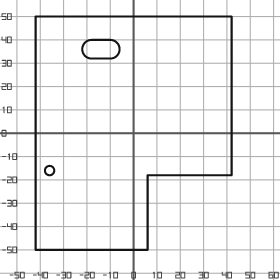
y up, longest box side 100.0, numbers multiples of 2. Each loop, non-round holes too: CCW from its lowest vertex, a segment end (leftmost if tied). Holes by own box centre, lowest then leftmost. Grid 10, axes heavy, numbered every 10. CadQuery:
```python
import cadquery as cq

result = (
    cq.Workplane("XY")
    .moveTo(-42.0, -50.0)
    .lineTo(6.0, -50.0)
    .lineTo(6.0, -18.0)
    .lineTo(42.0, -18.0)
    .lineTo(42.0, 50.0)
    .lineTo(-42.0, 50.0)
    .close()
    .moveTo(-36.0, -16.0)
    .circle(2.0)
    .moveTo(-18.0, 32.0)
    .lineTo(-10.0, 32.0)
    .threePointArc((-6.0, 36.0), (-10.0, 40.0))
    .lineTo(-18.0, 40.0)
    .threePointArc((-22.0, 36.0), (-18.0, 32.0))
    .close()
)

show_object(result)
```